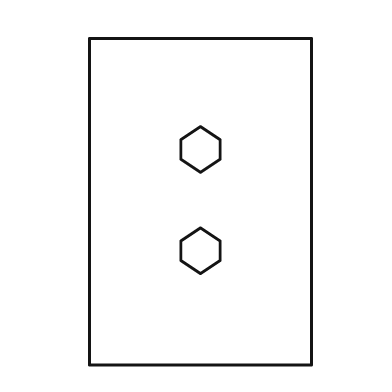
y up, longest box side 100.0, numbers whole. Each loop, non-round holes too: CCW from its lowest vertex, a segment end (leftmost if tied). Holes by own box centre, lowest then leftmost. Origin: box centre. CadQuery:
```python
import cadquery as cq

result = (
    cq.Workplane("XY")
    .moveTo(-34.0, -50.0)
    .lineTo(34.0, -50.0)
    .lineTo(34.0, 50.0)
    .lineTo(-34.0, 50.0)
    .close()
    .moveTo(0.0, -22.0)
    .lineTo(6.0, -18.0)
    .lineTo(6.0, -12.0)
    .lineTo(0.0, -8.0)
    .lineTo(-6.0, -12.0)
    .lineTo(-6.0, -18.0)
    .close()
    .moveTo(0.0, 9.0)
    .lineTo(6.0, 13.0)
    .lineTo(6.0, 19.0)
    .lineTo(0.0, 23.0)
    .lineTo(-6.0, 19.0)
    .lineTo(-6.0, 13.0)
    .close()
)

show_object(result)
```